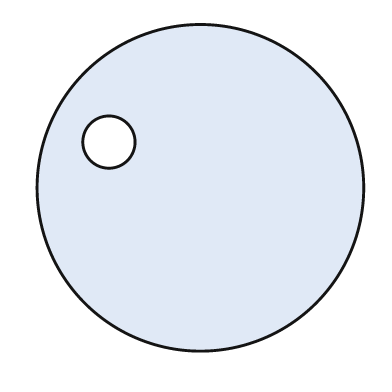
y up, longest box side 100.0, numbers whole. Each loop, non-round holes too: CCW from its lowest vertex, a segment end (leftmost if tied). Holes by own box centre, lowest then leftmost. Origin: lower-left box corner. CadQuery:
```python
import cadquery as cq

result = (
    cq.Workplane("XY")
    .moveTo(50.0, 50.0)
    .circle(50.0)
    .moveTo(22.0, 64.0)
    .circle(8.0)
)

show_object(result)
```